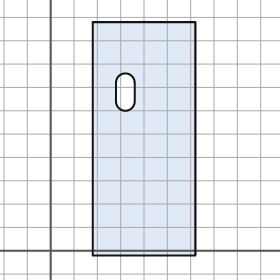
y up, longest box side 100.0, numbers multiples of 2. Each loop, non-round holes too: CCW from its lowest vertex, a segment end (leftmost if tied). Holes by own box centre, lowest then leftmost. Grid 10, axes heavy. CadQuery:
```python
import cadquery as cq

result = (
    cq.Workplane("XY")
    .moveTo(18.0, -2.0)
    .lineTo(62.0, -2.0)
    .lineTo(62.0, 98.0)
    .lineTo(18.0, 98.0)
    .close()
    .moveTo(28.0, 64.0)
    .threePointArc((32.0, 60.0), (36.0, 64.0))
    .lineTo(36.0, 72.0)
    .threePointArc((32.0, 76.0), (28.0, 72.0))
    .close()
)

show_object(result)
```